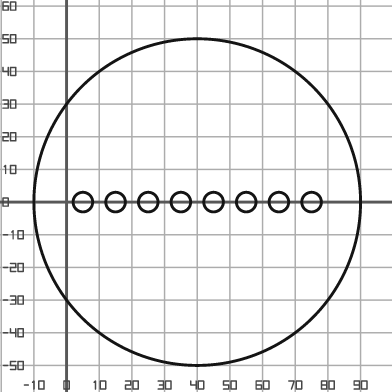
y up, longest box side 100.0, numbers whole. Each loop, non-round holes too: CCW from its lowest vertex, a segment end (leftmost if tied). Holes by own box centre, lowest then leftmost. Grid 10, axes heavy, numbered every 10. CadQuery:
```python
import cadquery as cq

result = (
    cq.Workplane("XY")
    .moveTo(40.0, 0.0)
    .circle(50.0)
    .moveTo(5.0, 0.0)
    .circle(3.0)
    .moveTo(15.0, 0.0)
    .circle(3.0)
    .moveTo(25.0, 0.0)
    .circle(3.0)
    .moveTo(35.0, 0.0)
    .circle(3.0)
    .moveTo(45.0, 0.0)
    .circle(3.0)
    .moveTo(55.0, 0.0)
    .circle(3.0)
    .moveTo(65.0, 0.0)
    .circle(3.0)
    .moveTo(75.0, 0.0)
    .circle(3.0)
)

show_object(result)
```